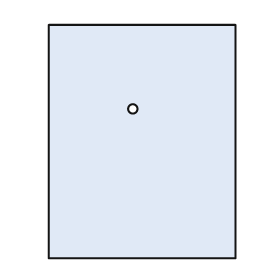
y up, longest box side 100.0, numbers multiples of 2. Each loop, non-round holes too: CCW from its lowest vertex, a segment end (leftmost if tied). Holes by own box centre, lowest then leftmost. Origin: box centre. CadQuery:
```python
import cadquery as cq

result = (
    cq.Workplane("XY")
    .moveTo(-40.0, -50.0)
    .lineTo(40.0, -50.0)
    .lineTo(40.0, 50.0)
    .lineTo(-40.0, 50.0)
    .close()
    .moveTo(-4.0, 14.0)
    .circle(2.0)
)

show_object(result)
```